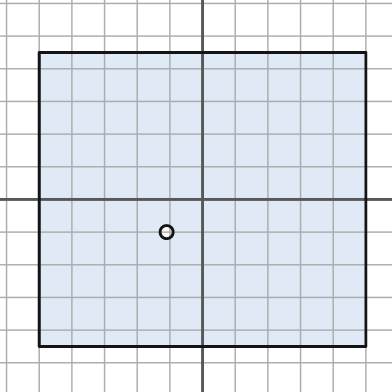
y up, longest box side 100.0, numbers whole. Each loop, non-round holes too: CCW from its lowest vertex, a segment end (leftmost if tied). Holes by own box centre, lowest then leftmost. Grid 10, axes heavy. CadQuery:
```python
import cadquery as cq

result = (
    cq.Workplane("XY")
    .moveTo(-50.0, -45.0)
    .lineTo(50.0, -45.0)
    .lineTo(50.0, 45.0)
    .lineTo(-50.0, 45.0)
    .close()
    .moveTo(-11.0, -10.0)
    .circle(2.0)
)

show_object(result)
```